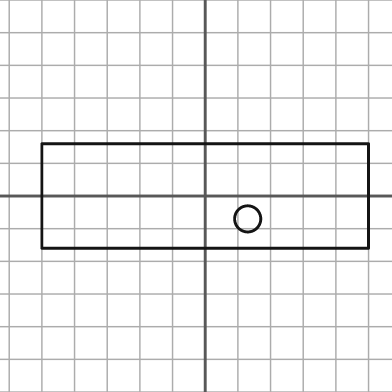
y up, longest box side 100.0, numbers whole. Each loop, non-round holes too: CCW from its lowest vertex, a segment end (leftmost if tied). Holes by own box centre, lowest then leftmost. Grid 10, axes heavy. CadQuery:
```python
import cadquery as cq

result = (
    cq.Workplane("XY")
    .moveTo(-50.0, -16.0)
    .lineTo(50.0, -16.0)
    .lineTo(50.0, 16.0)
    .lineTo(-50.0, 16.0)
    .close()
    .moveTo(13.0, -7.0)
    .circle(4.0)
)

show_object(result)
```